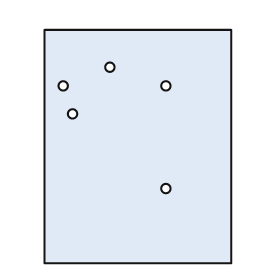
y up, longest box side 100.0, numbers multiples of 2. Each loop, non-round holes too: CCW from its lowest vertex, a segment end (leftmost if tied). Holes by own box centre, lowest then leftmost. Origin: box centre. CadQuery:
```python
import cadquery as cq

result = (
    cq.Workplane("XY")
    .moveTo(-40.0, -50.0)
    .lineTo(40.0, -50.0)
    .lineTo(40.0, 50.0)
    .lineTo(-40.0, 50.0)
    .close()
    .moveTo(12.0, -18.0)
    .circle(2.0)
    .moveTo(-28.0, 14.0)
    .circle(2.0)
    .moveTo(-32.0, 26.0)
    .circle(2.0)
    .moveTo(12.0, 26.0)
    .circle(2.0)
    .moveTo(-12.0, 34.0)
    .circle(2.0)
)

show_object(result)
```